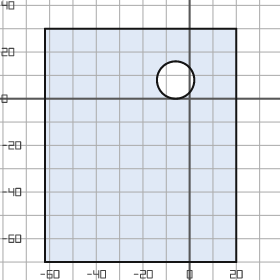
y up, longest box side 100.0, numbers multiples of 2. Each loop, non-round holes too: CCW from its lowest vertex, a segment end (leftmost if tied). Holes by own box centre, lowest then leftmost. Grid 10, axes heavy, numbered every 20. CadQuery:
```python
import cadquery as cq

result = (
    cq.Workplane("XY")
    .moveTo(-62.0, -70.0)
    .lineTo(20.0, -70.0)
    .lineTo(20.0, 30.0)
    .lineTo(-62.0, 30.0)
    .close()
    .moveTo(-6.0, 8.0)
    .circle(8.0)
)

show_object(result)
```